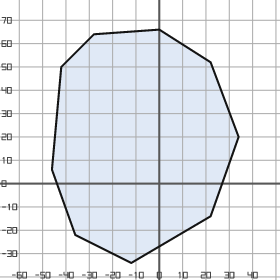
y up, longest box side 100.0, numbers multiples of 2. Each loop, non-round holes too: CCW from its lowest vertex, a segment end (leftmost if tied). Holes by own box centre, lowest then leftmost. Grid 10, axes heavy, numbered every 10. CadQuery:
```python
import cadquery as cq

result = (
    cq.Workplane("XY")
    .moveTo(-12.0, -34.0)
    .lineTo(22.0, -14.0)
    .lineTo(34.0, 20.0)
    .lineTo(22.0, 52.0)
    .lineTo(0.0, 66.0)
    .lineTo(-28.0, 64.0)
    .lineTo(-42.0, 50.0)
    .lineTo(-46.0, 6.0)
    .lineTo(-36.0, -22.0)
    .close()
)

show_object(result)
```